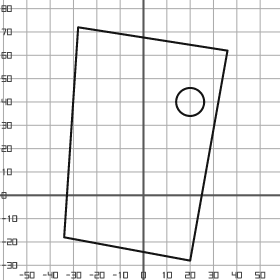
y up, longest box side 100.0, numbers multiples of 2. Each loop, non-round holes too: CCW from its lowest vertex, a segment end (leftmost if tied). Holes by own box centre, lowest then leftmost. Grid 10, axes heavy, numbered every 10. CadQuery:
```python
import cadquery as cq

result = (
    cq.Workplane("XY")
    .moveTo(20.0, -28.0)
    .lineTo(36.0, 62.0)
    .lineTo(-28.0, 72.0)
    .lineTo(-34.0, -18.0)
    .close()
    .moveTo(20.0, 40.0)
    .circle(6.0)
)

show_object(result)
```